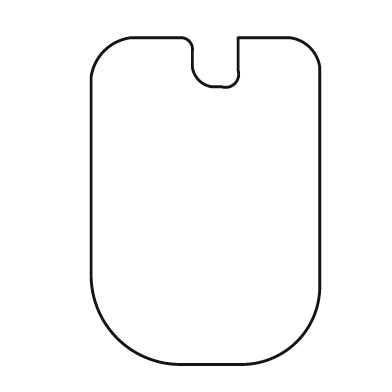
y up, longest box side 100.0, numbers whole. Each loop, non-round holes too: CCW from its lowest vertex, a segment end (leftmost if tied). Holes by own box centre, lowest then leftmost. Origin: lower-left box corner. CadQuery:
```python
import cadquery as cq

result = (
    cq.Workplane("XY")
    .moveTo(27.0, 0.0)
    .lineTo(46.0, 0.0)
    .threePointArc((63.0, 7.0), (70.0, 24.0))
    .lineTo(70.0, 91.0)
    .threePointArc((67.0, 97.0), (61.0, 100.0))
    .lineTo(45.0, 100.0)
    .lineTo(45.0, 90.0)
    .threePointArc((44.0, 86.0), (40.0, 85.0))
    .lineTo(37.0, 85.0)
    .threePointArc((33.0, 87.0), (31.0, 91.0))
    .lineTo(31.0, 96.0)
    .threePointArc((30.0, 99.0), (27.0, 100.0))
    .lineTo(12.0, 100.0)
    .threePointArc((4.0, 96.0), (0.0, 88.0))
    .lineTo(0.0, 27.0)
    .threePointArc((8.0, 8.0), (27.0, 0.0))
    .close()
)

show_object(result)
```